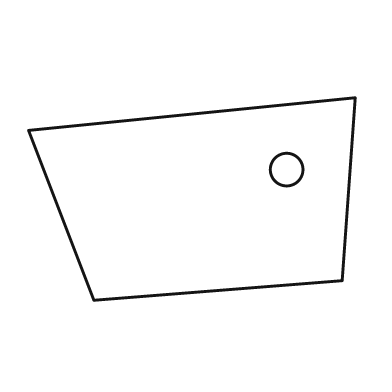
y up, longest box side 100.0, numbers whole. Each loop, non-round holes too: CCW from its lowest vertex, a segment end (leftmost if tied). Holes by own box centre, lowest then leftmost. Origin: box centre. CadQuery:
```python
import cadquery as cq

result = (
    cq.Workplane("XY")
    .moveTo(-30.0, -31.0)
    .lineTo(46.0, -25.0)
    .lineTo(50.0, 31.0)
    .lineTo(-50.0, 21.0)
    .close()
    .moveTo(29.0, 9.0)
    .circle(5.0)
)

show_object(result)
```